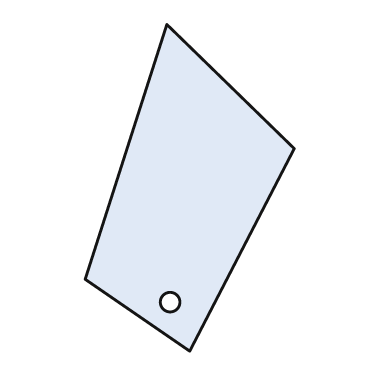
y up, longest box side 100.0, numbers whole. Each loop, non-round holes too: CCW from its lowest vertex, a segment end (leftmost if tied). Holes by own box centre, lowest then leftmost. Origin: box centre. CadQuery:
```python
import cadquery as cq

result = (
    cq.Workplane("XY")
    .moveTo(0.0, -50.0)
    .lineTo(32.0, 12.0)
    .lineTo(-7.0, 50.0)
    .lineTo(-32.0, -28.0)
    .close()
    .moveTo(-6.0, -35.0)
    .circle(3.0)
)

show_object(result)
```